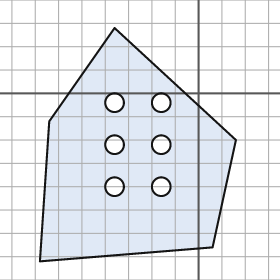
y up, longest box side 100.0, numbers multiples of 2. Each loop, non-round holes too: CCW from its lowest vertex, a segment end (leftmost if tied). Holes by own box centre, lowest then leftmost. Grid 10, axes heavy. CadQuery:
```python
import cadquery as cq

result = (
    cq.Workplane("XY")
    .moveTo(-68.0, -72.0)
    .lineTo(6.0, -66.0)
    .lineTo(16.0, -20.0)
    .lineTo(-36.0, 28.0)
    .lineTo(-64.0, -12.0)
    .close()
    .moveTo(-36.0, -40.0)
    .circle(4.0)
    .moveTo(-16.0, -40.0)
    .circle(4.0)
    .moveTo(-36.0, -22.0)
    .circle(4.0)
    .moveTo(-16.0, -22.0)
    .circle(4.0)
    .moveTo(-36.0, -4.0)
    .circle(4.0)
    .moveTo(-16.0, -4.0)
    .circle(4.0)
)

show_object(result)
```